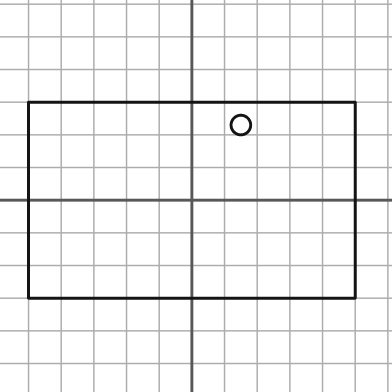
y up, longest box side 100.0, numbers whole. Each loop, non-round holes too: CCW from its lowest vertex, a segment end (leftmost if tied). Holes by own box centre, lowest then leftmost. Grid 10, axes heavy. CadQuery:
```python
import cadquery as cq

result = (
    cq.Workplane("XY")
    .moveTo(-50.0, -30.0)
    .lineTo(50.0, -30.0)
    .lineTo(50.0, 30.0)
    .lineTo(-50.0, 30.0)
    .close()
    .moveTo(15.0, 23.0)
    .circle(3.0)
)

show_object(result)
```